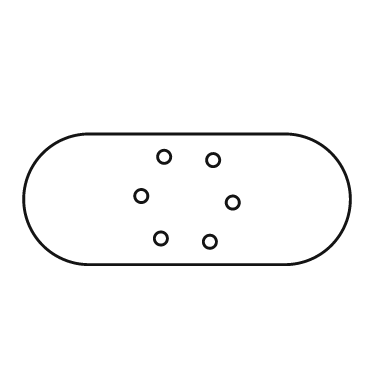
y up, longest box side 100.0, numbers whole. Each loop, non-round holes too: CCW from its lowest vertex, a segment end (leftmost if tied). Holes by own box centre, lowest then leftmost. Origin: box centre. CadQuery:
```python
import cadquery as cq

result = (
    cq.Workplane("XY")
    .moveTo(-30.0, -20.0)
    .lineTo(30.0, -20.0)
    .threePointArc((50.0, 0.0), (30.0, 20.0))
    .lineTo(-30.0, 20.0)
    .threePointArc((-50.0, 0.0), (-30.0, -20.0))
    .close()
    .moveTo(7.0, -13.0)
    .circle(2.0)
    .moveTo(-8.0, -12.0)
    .circle(2.0)
    .moveTo(14.0, -1.0)
    .circle(2.0)
    .moveTo(-14.0, 1.0)
    .circle(2.0)
    .moveTo(8.0, 12.0)
    .circle(2.0)
    .moveTo(-7.0, 13.0)
    .circle(2.0)
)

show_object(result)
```